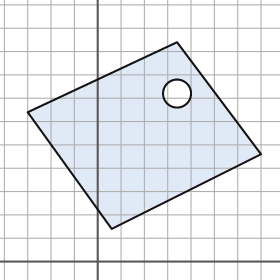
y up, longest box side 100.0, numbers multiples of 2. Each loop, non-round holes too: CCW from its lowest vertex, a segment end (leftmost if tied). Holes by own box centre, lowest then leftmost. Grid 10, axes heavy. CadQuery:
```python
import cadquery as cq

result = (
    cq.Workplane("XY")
    .moveTo(6.0, 14.0)
    .lineTo(70.0, 46.0)
    .lineTo(34.0, 94.0)
    .lineTo(-30.0, 64.0)
    .close()
    .moveTo(34.0, 72.0)
    .circle(6.0)
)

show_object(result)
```